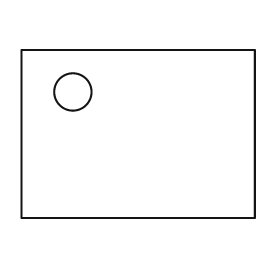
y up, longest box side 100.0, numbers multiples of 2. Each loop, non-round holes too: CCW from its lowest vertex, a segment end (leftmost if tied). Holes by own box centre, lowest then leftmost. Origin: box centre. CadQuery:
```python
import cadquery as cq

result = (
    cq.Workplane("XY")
    .moveTo(-50.0, -36.0)
    .lineTo(50.0, -36.0)
    .lineTo(50.0, 36.0)
    .lineTo(-50.0, 36.0)
    .close()
    .moveTo(-28.0, 18.0)
    .circle(8.0)
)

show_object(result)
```